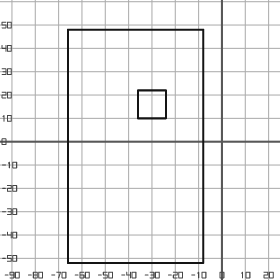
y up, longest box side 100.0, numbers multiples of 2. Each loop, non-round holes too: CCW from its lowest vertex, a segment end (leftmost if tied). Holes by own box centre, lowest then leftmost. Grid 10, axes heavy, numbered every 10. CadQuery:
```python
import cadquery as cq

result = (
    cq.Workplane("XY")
    .moveTo(-66.0, -52.0)
    .lineTo(-8.0, -52.0)
    .lineTo(-8.0, 48.0)
    .lineTo(-66.0, 48.0)
    .close()
    .moveTo(-36.0, 10.0)
    .lineTo(-24.0, 10.0)
    .lineTo(-24.0, 22.0)
    .lineTo(-36.0, 22.0)
    .close()
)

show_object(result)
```